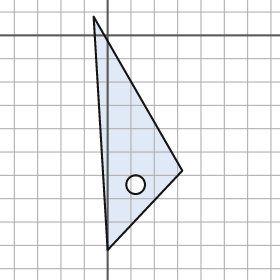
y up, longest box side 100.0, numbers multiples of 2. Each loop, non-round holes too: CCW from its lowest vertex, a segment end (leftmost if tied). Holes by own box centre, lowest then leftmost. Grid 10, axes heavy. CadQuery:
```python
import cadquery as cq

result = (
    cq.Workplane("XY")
    .moveTo(0.0, -92.0)
    .lineTo(32.0, -58.0)
    .lineTo(-6.0, 8.0)
    .close()
    .moveTo(12.0, -64.0)
    .circle(4.0)
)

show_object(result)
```